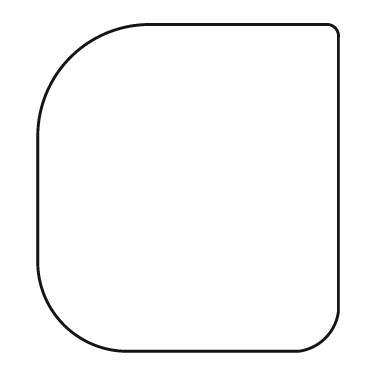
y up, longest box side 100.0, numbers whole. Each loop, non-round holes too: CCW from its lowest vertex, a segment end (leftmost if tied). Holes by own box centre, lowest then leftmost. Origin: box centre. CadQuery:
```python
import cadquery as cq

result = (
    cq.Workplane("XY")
    .moveTo(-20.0, -50.0)
    .lineTo(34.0, -50.0)
    .threePointArc((42.0, -46.0), (46.0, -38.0))
    .lineTo(46.0, 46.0)
    .threePointArc((45.0, 49.0), (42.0, 50.0))
    .lineTo(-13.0, 50.0)
    .threePointArc((-36.0, 40.0), (-46.0, 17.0))
    .lineTo(-46.0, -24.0)
    .threePointArc((-38.0, -42.0), (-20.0, -50.0))
    .close()
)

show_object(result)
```